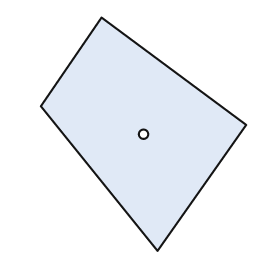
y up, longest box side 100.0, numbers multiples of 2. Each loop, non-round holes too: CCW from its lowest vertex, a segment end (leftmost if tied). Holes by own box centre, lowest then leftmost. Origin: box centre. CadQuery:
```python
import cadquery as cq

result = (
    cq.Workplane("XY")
    .moveTo(6.0, -50.0)
    .lineTo(44.0, 4.0)
    .lineTo(-18.0, 50.0)
    .lineTo(-44.0, 12.0)
    .close()
    .moveTo(0.0, 0.0)
    .circle(2.0)
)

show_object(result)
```